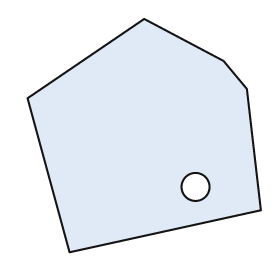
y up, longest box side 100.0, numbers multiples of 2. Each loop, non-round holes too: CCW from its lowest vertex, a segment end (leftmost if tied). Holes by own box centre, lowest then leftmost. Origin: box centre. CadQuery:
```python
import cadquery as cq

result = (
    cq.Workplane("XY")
    .moveTo(-32.0, -50.0)
    .lineTo(50.0, -32.0)
    .lineTo(44.0, 20.0)
    .lineTo(34.0, 32.0)
    .lineTo(0.0, 50.0)
    .lineTo(-50.0, 16.0)
    .close()
    .moveTo(22.0, -22.0)
    .circle(6.0)
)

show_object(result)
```